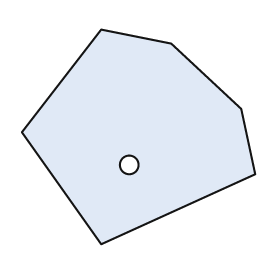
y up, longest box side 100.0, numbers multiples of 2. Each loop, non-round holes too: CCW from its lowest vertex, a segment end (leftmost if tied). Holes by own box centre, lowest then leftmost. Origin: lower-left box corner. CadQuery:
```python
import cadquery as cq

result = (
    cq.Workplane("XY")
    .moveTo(34.0, 0.0)
    .lineTo(100.0, 30.0)
    .lineTo(94.0, 58.0)
    .lineTo(64.0, 86.0)
    .lineTo(34.0, 92.0)
    .lineTo(0.0, 48.0)
    .close()
    .moveTo(46.0, 34.0)
    .circle(4.0)
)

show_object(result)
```